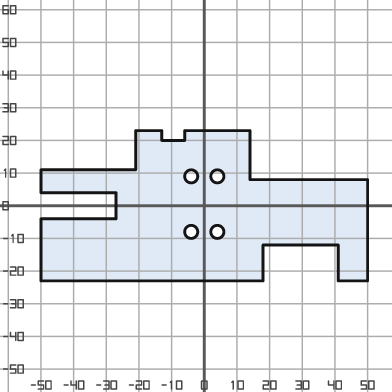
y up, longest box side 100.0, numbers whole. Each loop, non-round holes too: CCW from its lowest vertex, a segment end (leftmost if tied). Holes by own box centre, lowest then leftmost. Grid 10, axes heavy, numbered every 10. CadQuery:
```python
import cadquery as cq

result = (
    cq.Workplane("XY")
    .moveTo(-50.0, -23.0)
    .lineTo(18.0, -23.0)
    .lineTo(18.0, -12.0)
    .lineTo(41.0, -12.0)
    .lineTo(41.0, -23.0)
    .lineTo(50.0, -23.0)
    .lineTo(50.0, 8.0)
    .lineTo(14.0, 8.0)
    .lineTo(14.0, 23.0)
    .lineTo(-6.0, 23.0)
    .lineTo(-6.0, 20.0)
    .lineTo(-13.0, 20.0)
    .lineTo(-13.0, 23.0)
    .lineTo(-21.0, 23.0)
    .lineTo(-21.0, 11.0)
    .lineTo(-50.0, 11.0)
    .lineTo(-50.0, 4.0)
    .lineTo(-27.0, 4.0)
    .lineTo(-27.0, -4.0)
    .lineTo(-50.0, -4.0)
    .close()
    .moveTo(-4.0, -8.0)
    .circle(2.0)
    .moveTo(4.0, -8.0)
    .circle(2.0)
    .moveTo(-4.0, 9.0)
    .circle(2.0)
    .moveTo(4.0, 9.0)
    .circle(2.0)
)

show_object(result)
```